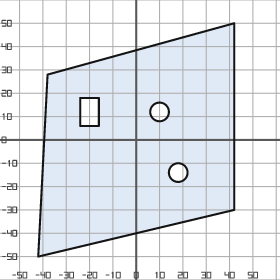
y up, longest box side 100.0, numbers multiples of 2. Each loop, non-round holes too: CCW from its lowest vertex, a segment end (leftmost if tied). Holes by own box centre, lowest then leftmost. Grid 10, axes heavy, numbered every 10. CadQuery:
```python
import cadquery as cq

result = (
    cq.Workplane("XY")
    .moveTo(-42.0, -50.0)
    .lineTo(42.0, -30.0)
    .lineTo(42.0, 50.0)
    .lineTo(-38.0, 28.0)
    .close()
    .moveTo(18.0, -14.0)
    .circle(4.0)
    .moveTo(-24.0, 6.0)
    .lineTo(-16.0, 6.0)
    .lineTo(-16.0, 18.0)
    .lineTo(-24.0, 18.0)
    .close()
    .moveTo(10.0, 12.0)
    .circle(4.0)
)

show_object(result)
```